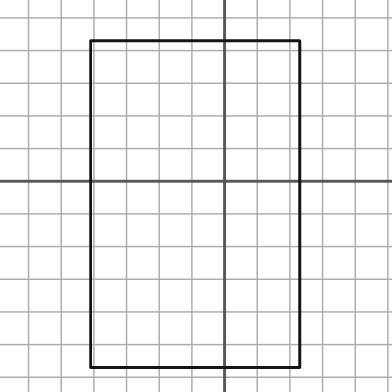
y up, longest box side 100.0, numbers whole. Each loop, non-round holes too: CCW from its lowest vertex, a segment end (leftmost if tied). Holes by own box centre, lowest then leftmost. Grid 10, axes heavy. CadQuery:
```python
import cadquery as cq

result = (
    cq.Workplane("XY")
    .moveTo(-41.0, -57.0)
    .lineTo(23.0, -57.0)
    .lineTo(23.0, 43.0)
    .lineTo(-41.0, 43.0)
    .close()
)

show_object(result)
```